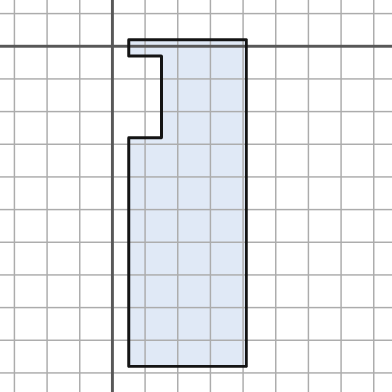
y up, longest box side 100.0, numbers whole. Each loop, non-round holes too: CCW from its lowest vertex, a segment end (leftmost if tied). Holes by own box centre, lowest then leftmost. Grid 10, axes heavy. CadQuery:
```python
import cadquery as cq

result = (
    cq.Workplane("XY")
    .moveTo(5.0, -98.0)
    .lineTo(41.0, -98.0)
    .lineTo(41.0, 2.0)
    .lineTo(5.0, 2.0)
    .lineTo(5.0, -3.0)
    .lineTo(15.0, -3.0)
    .lineTo(15.0, -28.0)
    .lineTo(5.0, -28.0)
    .close()
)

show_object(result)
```